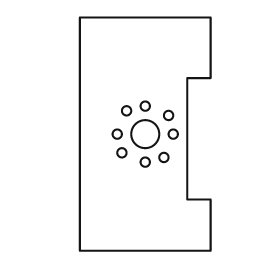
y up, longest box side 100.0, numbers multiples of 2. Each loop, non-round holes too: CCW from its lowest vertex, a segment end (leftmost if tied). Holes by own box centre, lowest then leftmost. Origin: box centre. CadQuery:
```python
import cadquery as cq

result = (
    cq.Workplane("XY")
    .moveTo(-28.0, -50.0)
    .lineTo(28.0, -50.0)
    .lineTo(28.0, -28.0)
    .lineTo(18.0, -28.0)
    .lineTo(18.0, 24.0)
    .lineTo(28.0, 24.0)
    .lineTo(28.0, 50.0)
    .lineTo(-28.0, 50.0)
    .close()
    .moveTo(0.0, -12.0)
    .circle(2.0)
    .moveTo(8.0, -10.0)
    .circle(2.0)
    .moveTo(-10.0, -8.0)
    .circle(2.0)
    .moveTo(-12.0, 0.0)
    .circle(2.0)
    .moveTo(0.0, 0.0)
    .circle(6.0)
    .moveTo(12.0, 0.0)
    .circle(2.0)
    .moveTo(10.0, 8.0)
    .circle(2.0)
    .moveTo(-8.0, 10.0)
    .circle(2.0)
    .moveTo(0.0, 12.0)
    .circle(2.0)
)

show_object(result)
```